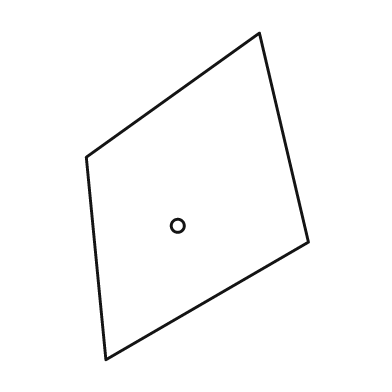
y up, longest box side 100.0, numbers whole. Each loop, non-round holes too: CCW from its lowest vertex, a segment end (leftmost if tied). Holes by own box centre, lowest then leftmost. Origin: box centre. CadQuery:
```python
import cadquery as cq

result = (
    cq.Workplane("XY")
    .moveTo(-28.0, -50.0)
    .lineTo(34.0, -14.0)
    .lineTo(19.0, 50.0)
    .lineTo(-34.0, 12.0)
    .close()
    .moveTo(-6.0, -9.0)
    .circle(2.0)
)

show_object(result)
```